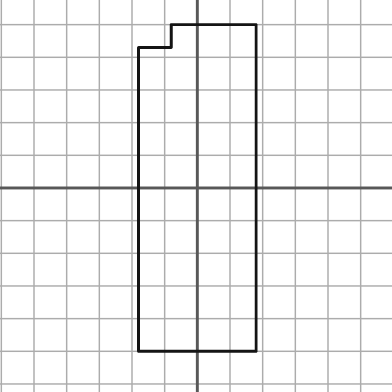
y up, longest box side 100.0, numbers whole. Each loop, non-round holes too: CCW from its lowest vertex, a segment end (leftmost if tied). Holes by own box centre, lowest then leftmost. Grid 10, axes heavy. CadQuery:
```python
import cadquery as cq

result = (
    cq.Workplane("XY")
    .moveTo(-18.0, -50.0)
    .lineTo(18.0, -50.0)
    .lineTo(18.0, 50.0)
    .lineTo(-8.0, 50.0)
    .lineTo(-8.0, 43.0)
    .lineTo(-18.0, 43.0)
    .close()
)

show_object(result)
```